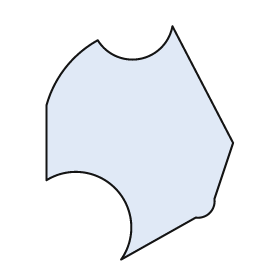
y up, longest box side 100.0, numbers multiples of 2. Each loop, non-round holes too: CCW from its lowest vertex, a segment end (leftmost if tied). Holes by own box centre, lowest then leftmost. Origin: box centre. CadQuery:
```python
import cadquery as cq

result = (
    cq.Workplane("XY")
    .moveTo(-8.0, -50.0)
    .lineTo(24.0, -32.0)
    .threePointArc((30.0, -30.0), (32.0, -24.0))
    .lineTo(40.0, 0.0)
    .lineTo(14.0, 50.0)
    .threePointArc((0.0, 36.0), (-18.0, 44.0))
    .threePointArc((-32.0, 32.0), (-40.0, 16.0))
    .lineTo(-40.0, -16.0)
    .threePointArc((-10.0, -20.0), (-8.0, -50.0))
    .close()
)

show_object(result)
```